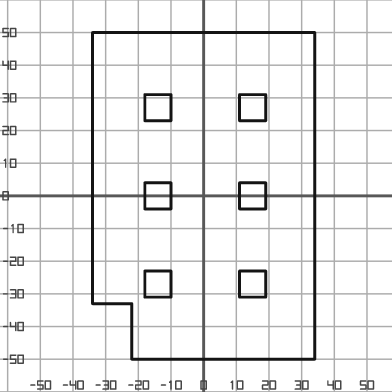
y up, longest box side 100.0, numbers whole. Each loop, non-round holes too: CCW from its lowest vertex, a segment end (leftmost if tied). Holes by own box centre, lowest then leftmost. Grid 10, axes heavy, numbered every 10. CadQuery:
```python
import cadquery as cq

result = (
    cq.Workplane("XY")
    .moveTo(-22.0, -50.0)
    .lineTo(34.0, -50.0)
    .lineTo(34.0, 50.0)
    .lineTo(-34.0, 50.0)
    .lineTo(-34.0, -33.0)
    .lineTo(-22.0, -33.0)
    .close()
    .moveTo(-18.0, -31.0)
    .lineTo(-10.0, -31.0)
    .lineTo(-10.0, -23.0)
    .lineTo(-18.0, -23.0)
    .close()
    .moveTo(11.0, -31.0)
    .lineTo(19.0, -31.0)
    .lineTo(19.0, -23.0)
    .lineTo(11.0, -23.0)
    .close()
    .moveTo(-18.0, -4.0)
    .lineTo(-10.0, -4.0)
    .lineTo(-10.0, 4.0)
    .lineTo(-18.0, 4.0)
    .close()
    .moveTo(11.0, -4.0)
    .lineTo(19.0, -4.0)
    .lineTo(19.0, 4.0)
    .lineTo(11.0, 4.0)
    .close()
    .moveTo(-18.0, 23.0)
    .lineTo(-10.0, 23.0)
    .lineTo(-10.0, 31.0)
    .lineTo(-18.0, 31.0)
    .close()
    .moveTo(11.0, 23.0)
    .lineTo(19.0, 23.0)
    .lineTo(19.0, 31.0)
    .lineTo(11.0, 31.0)
    .close()
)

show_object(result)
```